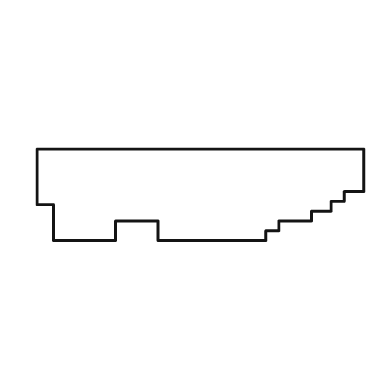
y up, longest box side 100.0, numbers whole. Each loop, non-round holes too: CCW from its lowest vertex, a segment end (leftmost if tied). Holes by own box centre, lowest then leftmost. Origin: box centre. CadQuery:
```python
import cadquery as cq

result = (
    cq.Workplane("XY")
    .moveTo(-45.0, -14.0)
    .lineTo(-26.0, -14.0)
    .lineTo(-26.0, -8.0)
    .lineTo(-13.0, -8.0)
    .lineTo(-13.0, -14.0)
    .lineTo(20.0, -14.0)
    .lineTo(20.0, -11.0)
    .lineTo(24.0, -11.0)
    .lineTo(24.0, -8.0)
    .lineTo(34.0, -8.0)
    .lineTo(34.0, -5.0)
    .lineTo(40.0, -5.0)
    .lineTo(40.0, -2.0)
    .lineTo(44.0, -2.0)
    .lineTo(44.0, 1.0)
    .lineTo(50.0, 1.0)
    .lineTo(50.0, 14.0)
    .lineTo(-50.0, 14.0)
    .lineTo(-50.0, -3.0)
    .lineTo(-45.0, -3.0)
    .close()
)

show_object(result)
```